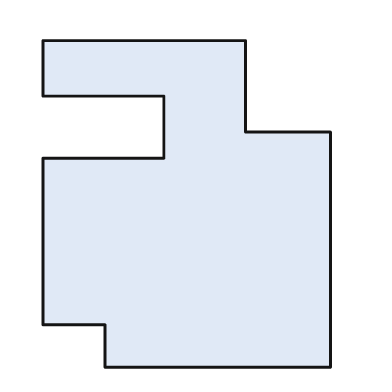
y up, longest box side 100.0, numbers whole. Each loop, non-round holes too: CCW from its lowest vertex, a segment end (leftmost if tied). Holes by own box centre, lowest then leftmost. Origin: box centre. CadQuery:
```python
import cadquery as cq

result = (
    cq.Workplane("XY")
    .moveTo(-25.0, -50.0)
    .lineTo(44.0, -50.0)
    .lineTo(44.0, 22.0)
    .lineTo(18.0, 22.0)
    .lineTo(18.0, 50.0)
    .lineTo(-44.0, 50.0)
    .lineTo(-44.0, 33.0)
    .lineTo(-7.0, 33.0)
    .lineTo(-7.0, 14.0)
    .lineTo(-44.0, 14.0)
    .lineTo(-44.0, -37.0)
    .lineTo(-25.0, -37.0)
    .close()
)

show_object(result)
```